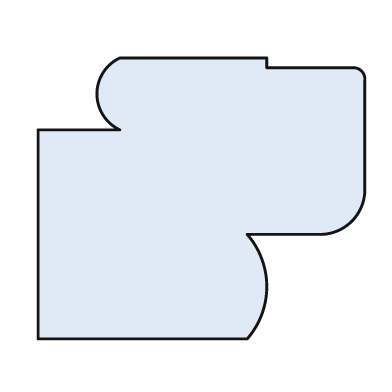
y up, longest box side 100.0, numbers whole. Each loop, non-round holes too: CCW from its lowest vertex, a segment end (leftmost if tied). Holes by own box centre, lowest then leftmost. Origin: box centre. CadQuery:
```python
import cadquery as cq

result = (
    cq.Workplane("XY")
    .moveTo(-50.0, -43.0)
    .lineTo(14.0, -43.0)
    .threePointArc((20.0, -27.0), (14.0, -11.0))
    .lineTo(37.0, -11.0)
    .threePointArc((46.0, -7.0), (50.0, 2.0))
    .lineTo(50.0, 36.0)
    .threePointArc((49.0, 39.0), (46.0, 40.0))
    .lineTo(20.0, 40.0)
    .lineTo(20.0, 43.0)
    .lineTo(-25.0, 43.0)
    .threePointArc((-32.0, 32.0), (-25.0, 21.0))
    .lineTo(-50.0, 21.0)
    .close()
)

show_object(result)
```